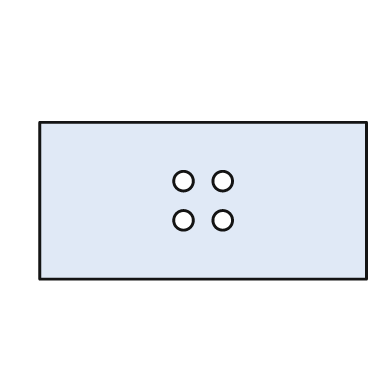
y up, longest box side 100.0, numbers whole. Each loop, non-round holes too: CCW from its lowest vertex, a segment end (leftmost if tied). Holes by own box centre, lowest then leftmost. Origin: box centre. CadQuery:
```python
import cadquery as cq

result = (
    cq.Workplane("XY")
    .moveTo(-50.0, -24.0)
    .lineTo(50.0, -24.0)
    .lineTo(50.0, 24.0)
    .lineTo(-50.0, 24.0)
    .close()
    .moveTo(-6.0, -6.0)
    .circle(3.0)
    .moveTo(6.0, -6.0)
    .circle(3.0)
    .moveTo(-6.0, 6.0)
    .circle(3.0)
    .moveTo(6.0, 6.0)
    .circle(3.0)
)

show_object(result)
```